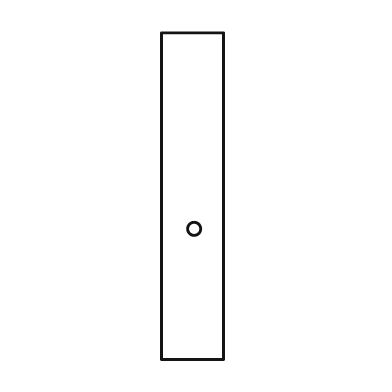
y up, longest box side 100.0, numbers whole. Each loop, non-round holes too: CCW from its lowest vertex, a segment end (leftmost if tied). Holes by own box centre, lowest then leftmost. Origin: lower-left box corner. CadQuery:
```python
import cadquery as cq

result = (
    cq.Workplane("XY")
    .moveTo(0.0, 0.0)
    .lineTo(19.0, 0.0)
    .lineTo(19.0, 100.0)
    .lineTo(0.0, 100.0)
    .close()
    .moveTo(10.0, 40.0)
    .circle(2.0)
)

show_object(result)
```